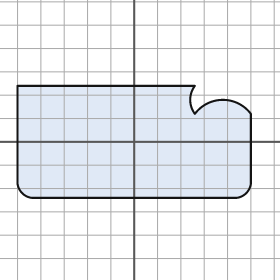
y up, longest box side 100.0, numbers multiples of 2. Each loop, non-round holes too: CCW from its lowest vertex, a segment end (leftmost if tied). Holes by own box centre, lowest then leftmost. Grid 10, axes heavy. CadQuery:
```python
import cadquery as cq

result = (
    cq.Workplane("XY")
    .moveTo(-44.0, -24.0)
    .lineTo(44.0, -24.0)
    .threePointArc((48.0, -22.0), (50.0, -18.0))
    .lineTo(50.0, 12.0)
    .threePointArc((38.0, 18.0), (26.0, 12.0))
    .threePointArc((24.0, 18.0), (26.0, 24.0))
    .lineTo(-50.0, 24.0)
    .lineTo(-50.0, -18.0)
    .threePointArc((-48.0, -22.0), (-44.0, -24.0))
    .close()
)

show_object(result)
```